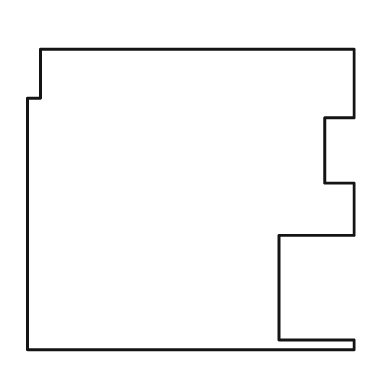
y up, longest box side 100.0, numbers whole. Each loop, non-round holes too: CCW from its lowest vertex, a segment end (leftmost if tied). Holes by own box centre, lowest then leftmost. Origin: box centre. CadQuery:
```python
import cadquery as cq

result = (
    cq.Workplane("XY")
    .moveTo(-50.0, -46.0)
    .lineTo(50.0, -46.0)
    .lineTo(50.0, -43.0)
    .lineTo(27.0, -43.0)
    .lineTo(27.0, -11.0)
    .lineTo(50.0, -11.0)
    .lineTo(50.0, 5.0)
    .lineTo(41.0, 5.0)
    .lineTo(41.0, 25.0)
    .lineTo(50.0, 25.0)
    .lineTo(50.0, 46.0)
    .lineTo(-46.0, 46.0)
    .lineTo(-46.0, 31.0)
    .lineTo(-50.0, 31.0)
    .close()
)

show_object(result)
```